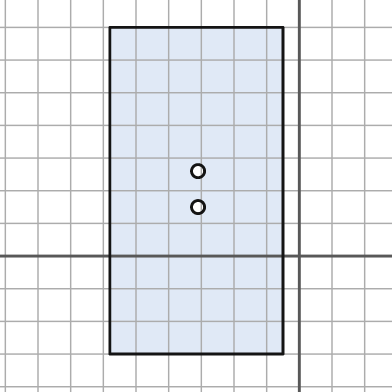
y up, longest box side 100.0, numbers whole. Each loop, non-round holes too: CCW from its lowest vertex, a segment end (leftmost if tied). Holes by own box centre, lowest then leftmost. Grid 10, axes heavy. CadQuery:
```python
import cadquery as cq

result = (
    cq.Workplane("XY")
    .moveTo(-58.0, -30.0)
    .lineTo(-5.0, -30.0)
    .lineTo(-5.0, 70.0)
    .lineTo(-58.0, 70.0)
    .close()
    .moveTo(-31.0, 15.0)
    .circle(2.0)
    .moveTo(-31.0, 26.0)
    .circle(2.0)
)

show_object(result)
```